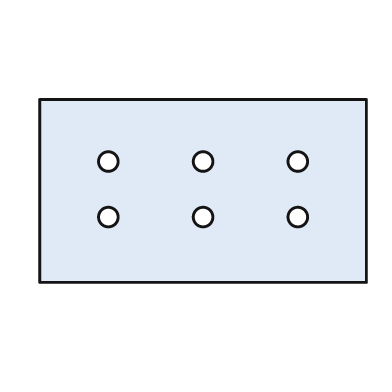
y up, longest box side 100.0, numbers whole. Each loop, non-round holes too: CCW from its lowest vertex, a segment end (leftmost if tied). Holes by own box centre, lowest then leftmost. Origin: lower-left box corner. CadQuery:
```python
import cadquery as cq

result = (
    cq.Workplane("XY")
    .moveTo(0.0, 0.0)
    .lineTo(100.0, 0.0)
    .lineTo(100.0, 56.0)
    .lineTo(0.0, 56.0)
    .close()
    .moveTo(21.0, 20.0)
    .circle(3.0)
    .moveTo(50.0, 20.0)
    .circle(3.0)
    .moveTo(79.0, 20.0)
    .circle(3.0)
    .moveTo(21.0, 37.0)
    .circle(3.0)
    .moveTo(50.0, 37.0)
    .circle(3.0)
    .moveTo(79.0, 37.0)
    .circle(3.0)
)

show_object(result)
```